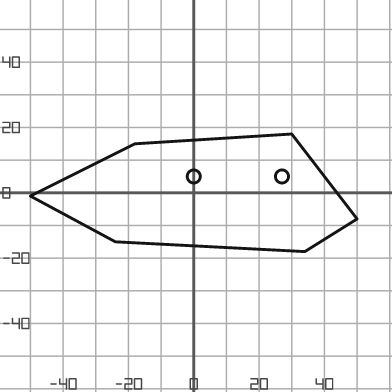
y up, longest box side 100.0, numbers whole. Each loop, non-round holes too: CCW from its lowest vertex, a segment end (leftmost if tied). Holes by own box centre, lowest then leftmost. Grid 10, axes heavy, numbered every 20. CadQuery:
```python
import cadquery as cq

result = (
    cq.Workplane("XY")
    .moveTo(34.0, -18.0)
    .lineTo(50.0, -8.0)
    .lineTo(30.0, 18.0)
    .lineTo(-18.0, 15.0)
    .lineTo(-50.0, -1.0)
    .lineTo(-24.0, -15.0)
    .close()
    .moveTo(0.0, 5.0)
    .circle(2.0)
    .moveTo(27.0, 5.0)
    .circle(2.0)
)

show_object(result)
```